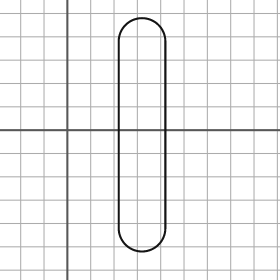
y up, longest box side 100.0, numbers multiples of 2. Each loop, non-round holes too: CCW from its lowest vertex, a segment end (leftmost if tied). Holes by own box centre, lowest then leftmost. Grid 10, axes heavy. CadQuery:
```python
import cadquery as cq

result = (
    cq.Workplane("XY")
    .moveTo(22.0, -42.0)
    .threePointArc((32.0, -52.0), (42.0, -42.0))
    .lineTo(42.0, 38.0)
    .threePointArc((32.0, 48.0), (22.0, 38.0))
    .close()
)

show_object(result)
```